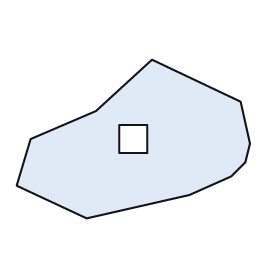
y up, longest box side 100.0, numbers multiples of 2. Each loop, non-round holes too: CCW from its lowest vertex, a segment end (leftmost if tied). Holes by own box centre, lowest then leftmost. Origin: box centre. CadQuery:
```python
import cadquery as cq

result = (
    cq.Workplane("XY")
    .moveTo(-20.0, -34.0)
    .lineTo(24.0, -24.0)
    .lineTo(42.0, -16.0)
    .lineTo(48.0, -10.0)
    .lineTo(50.0, -2.0)
    .lineTo(46.0, 16.0)
    .lineTo(8.0, 34.0)
    .lineTo(-16.0, 12.0)
    .lineTo(-44.0, 0.0)
    .lineTo(-50.0, -20.0)
    .close()
    .moveTo(-6.0, -6.0)
    .lineTo(6.0, -6.0)
    .lineTo(6.0, 6.0)
    .lineTo(-6.0, 6.0)
    .close()
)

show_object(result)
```